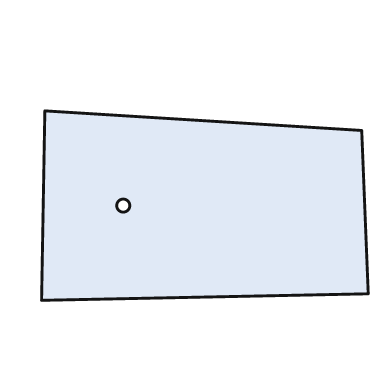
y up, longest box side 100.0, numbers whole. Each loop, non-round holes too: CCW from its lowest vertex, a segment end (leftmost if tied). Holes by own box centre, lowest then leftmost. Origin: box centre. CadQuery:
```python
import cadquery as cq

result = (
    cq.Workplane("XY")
    .moveTo(-50.0, -29.0)
    .lineTo(50.0, -27.0)
    .lineTo(48.0, 23.0)
    .lineTo(-49.0, 29.0)
    .close()
    .moveTo(-25.0, 0.0)
    .circle(2.0)
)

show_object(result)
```